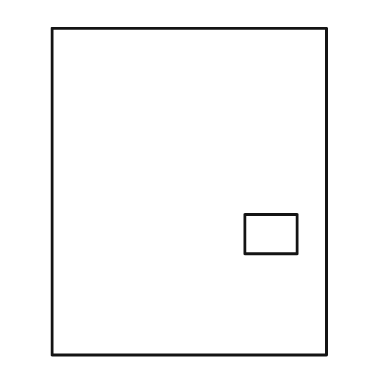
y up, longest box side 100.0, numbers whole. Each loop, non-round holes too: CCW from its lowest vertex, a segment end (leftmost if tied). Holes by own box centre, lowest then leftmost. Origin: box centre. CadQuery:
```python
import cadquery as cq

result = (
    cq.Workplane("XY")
    .moveTo(-42.0, -50.0)
    .lineTo(42.0, -50.0)
    .lineTo(42.0, 50.0)
    .lineTo(-42.0, 50.0)
    .close()
    .moveTo(17.0, -19.0)
    .lineTo(33.0, -19.0)
    .lineTo(33.0, -7.0)
    .lineTo(17.0, -7.0)
    .close()
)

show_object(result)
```